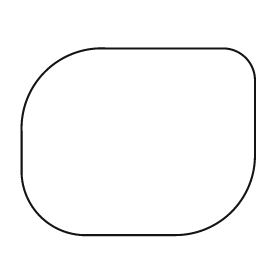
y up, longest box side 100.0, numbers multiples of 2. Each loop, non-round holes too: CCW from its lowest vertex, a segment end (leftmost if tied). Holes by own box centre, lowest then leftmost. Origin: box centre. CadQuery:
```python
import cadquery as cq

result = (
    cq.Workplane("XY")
    .moveTo(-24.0, -40.0)
    .lineTo(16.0, -40.0)
    .threePointArc((40.0, -30.0), (50.0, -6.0))
    .lineTo(50.0, 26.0)
    .threePointArc((46.0, 36.0), (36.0, 40.0))
    .lineTo(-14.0, 40.0)
    .threePointArc((-40.0, 30.0), (-50.0, 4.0))
    .lineTo(-50.0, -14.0)
    .threePointArc((-42.0, -32.0), (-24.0, -40.0))
    .close()
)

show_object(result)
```